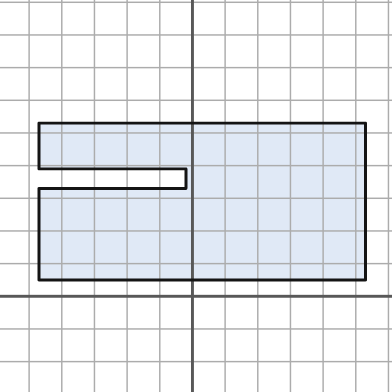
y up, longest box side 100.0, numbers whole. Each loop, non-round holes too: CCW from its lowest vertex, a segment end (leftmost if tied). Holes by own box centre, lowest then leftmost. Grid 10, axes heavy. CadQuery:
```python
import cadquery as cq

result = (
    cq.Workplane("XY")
    .moveTo(-47.0, 5.0)
    .lineTo(53.0, 5.0)
    .lineTo(53.0, 53.0)
    .lineTo(-47.0, 53.0)
    .lineTo(-47.0, 39.0)
    .lineTo(-2.0, 39.0)
    .lineTo(-2.0, 33.0)
    .lineTo(-47.0, 33.0)
    .close()
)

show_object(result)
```